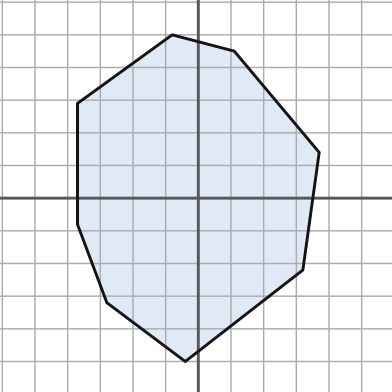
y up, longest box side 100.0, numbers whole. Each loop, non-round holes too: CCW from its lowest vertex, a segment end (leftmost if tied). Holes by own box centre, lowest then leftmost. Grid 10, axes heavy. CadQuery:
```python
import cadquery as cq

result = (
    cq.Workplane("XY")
    .moveTo(-4.0, -50.0)
    .lineTo(32.0, -22.0)
    .lineTo(37.0, 14.0)
    .lineTo(11.0, 45.0)
    .lineTo(-8.0, 50.0)
    .lineTo(-37.0, 29.0)
    .lineTo(-37.0, -8.0)
    .lineTo(-28.0, -32.0)
    .close()
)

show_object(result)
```